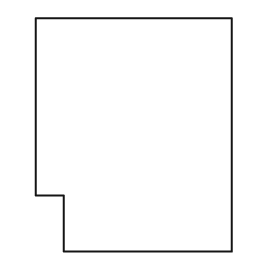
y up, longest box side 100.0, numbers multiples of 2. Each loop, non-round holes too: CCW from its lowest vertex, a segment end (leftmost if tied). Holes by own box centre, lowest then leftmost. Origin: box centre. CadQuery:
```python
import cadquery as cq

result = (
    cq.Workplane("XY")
    .moveTo(-30.0, -50.0)
    .lineTo(42.0, -50.0)
    .lineTo(42.0, 50.0)
    .lineTo(-42.0, 50.0)
    .lineTo(-42.0, -26.0)
    .lineTo(-30.0, -26.0)
    .close()
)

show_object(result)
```